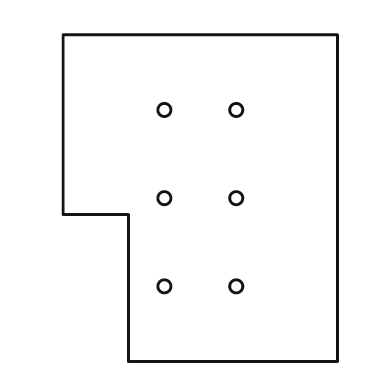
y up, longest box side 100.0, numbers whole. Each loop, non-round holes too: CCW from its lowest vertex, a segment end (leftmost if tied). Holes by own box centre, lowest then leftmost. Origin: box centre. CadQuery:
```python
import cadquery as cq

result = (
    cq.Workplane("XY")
    .moveTo(-22.0, -50.0)
    .lineTo(42.0, -50.0)
    .lineTo(42.0, 50.0)
    .lineTo(-42.0, 50.0)
    .lineTo(-42.0, -5.0)
    .lineTo(-22.0, -5.0)
    .close()
    .moveTo(-11.0, -27.0)
    .circle(2.0)
    .moveTo(11.0, -27.0)
    .circle(2.0)
    .moveTo(-11.0, 0.0)
    .circle(2.0)
    .moveTo(11.0, 0.0)
    .circle(2.0)
    .moveTo(-11.0, 27.0)
    .circle(2.0)
    .moveTo(11.0, 27.0)
    .circle(2.0)
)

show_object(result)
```